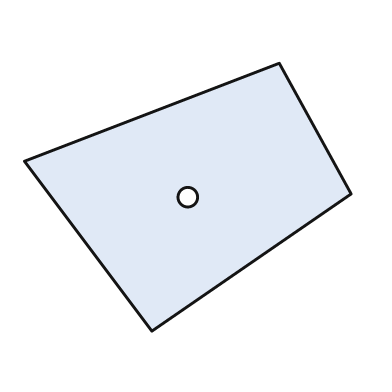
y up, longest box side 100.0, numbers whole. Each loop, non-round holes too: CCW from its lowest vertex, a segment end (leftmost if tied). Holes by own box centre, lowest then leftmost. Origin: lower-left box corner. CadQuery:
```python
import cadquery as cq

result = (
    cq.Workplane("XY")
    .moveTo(39.0, 0.0)
    .lineTo(100.0, 42.0)
    .lineTo(78.0, 82.0)
    .lineTo(0.0, 52.0)
    .close()
    .moveTo(50.0, 41.0)
    .circle(3.0)
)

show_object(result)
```